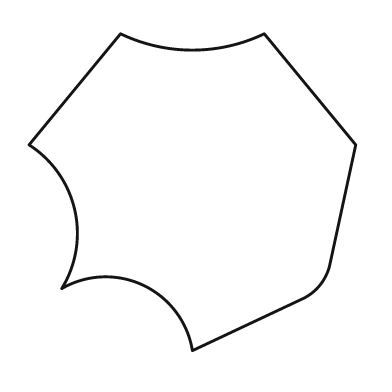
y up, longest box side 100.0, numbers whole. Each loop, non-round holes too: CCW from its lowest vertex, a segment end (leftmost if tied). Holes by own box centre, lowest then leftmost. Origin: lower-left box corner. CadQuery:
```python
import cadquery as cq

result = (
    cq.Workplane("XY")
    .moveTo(50.0, 0.0)
    .lineTo(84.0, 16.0)
    .threePointArc((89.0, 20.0), (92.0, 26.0))
    .lineTo(100.0, 63.0)
    .lineTo(72.0, 97.0)
    .threePointArc((50.0, 92.0), (28.0, 97.0))
    .lineTo(0.0, 63.0)
    .threePointArc((14.0, 43.0), (10.0, 19.0))
    .threePointArc((35.0, 20.0), (50.0, 0.0))
    .close()
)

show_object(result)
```